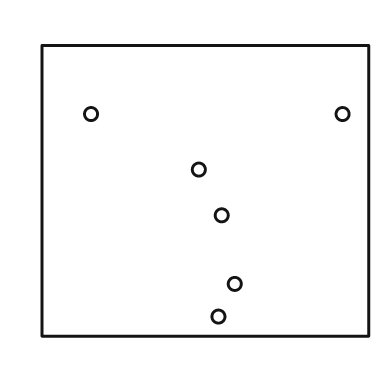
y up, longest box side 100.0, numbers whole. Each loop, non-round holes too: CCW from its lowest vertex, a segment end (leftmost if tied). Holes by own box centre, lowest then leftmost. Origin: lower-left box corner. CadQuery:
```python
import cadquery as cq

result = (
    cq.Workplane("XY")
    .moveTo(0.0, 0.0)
    .lineTo(100.0, 0.0)
    .lineTo(100.0, 89.0)
    .lineTo(0.0, 89.0)
    .close()
    .moveTo(54.0, 6.0)
    .circle(2.0)
    .moveTo(59.0, 16.0)
    .circle(2.0)
    .moveTo(55.0, 37.0)
    .circle(2.0)
    .moveTo(48.0, 51.0)
    .circle(2.0)
    .moveTo(15.0, 68.0)
    .circle(2.0)
    .moveTo(92.0, 68.0)
    .circle(2.0)
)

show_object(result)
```